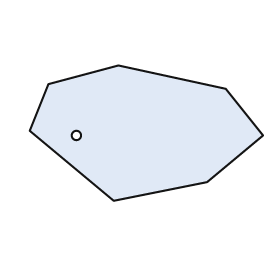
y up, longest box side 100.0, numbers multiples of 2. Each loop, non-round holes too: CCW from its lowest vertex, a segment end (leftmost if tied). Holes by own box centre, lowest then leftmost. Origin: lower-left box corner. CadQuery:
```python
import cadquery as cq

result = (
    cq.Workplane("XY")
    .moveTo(36.0, 0.0)
    .lineTo(76.0, 8.0)
    .lineTo(100.0, 28.0)
    .lineTo(84.0, 48.0)
    .lineTo(38.0, 58.0)
    .lineTo(8.0, 50.0)
    .lineTo(0.0, 30.0)
    .close()
    .moveTo(20.0, 28.0)
    .circle(2.0)
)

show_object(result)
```